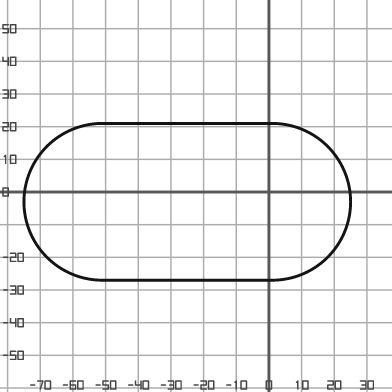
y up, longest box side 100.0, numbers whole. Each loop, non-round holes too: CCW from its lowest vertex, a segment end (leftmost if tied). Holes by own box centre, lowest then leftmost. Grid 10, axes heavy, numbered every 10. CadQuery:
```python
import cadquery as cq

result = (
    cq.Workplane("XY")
    .moveTo(-51.0, -27.0)
    .lineTo(1.0, -27.0)
    .threePointArc((25.0, -3.0), (1.0, 21.0))
    .lineTo(-51.0, 21.0)
    .threePointArc((-75.0, -3.0), (-51.0, -27.0))
    .close()
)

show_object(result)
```